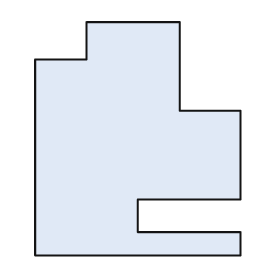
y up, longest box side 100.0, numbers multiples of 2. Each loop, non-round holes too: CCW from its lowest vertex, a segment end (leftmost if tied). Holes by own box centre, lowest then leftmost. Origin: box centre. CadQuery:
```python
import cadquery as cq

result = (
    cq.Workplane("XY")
    .moveTo(-44.0, -50.0)
    .lineTo(44.0, -50.0)
    .lineTo(44.0, -40.0)
    .lineTo(0.0, -40.0)
    .lineTo(0.0, -26.0)
    .lineTo(44.0, -26.0)
    .lineTo(44.0, 12.0)
    .lineTo(18.0, 12.0)
    .lineTo(18.0, 50.0)
    .lineTo(-22.0, 50.0)
    .lineTo(-22.0, 34.0)
    .lineTo(-44.0, 34.0)
    .close()
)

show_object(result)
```